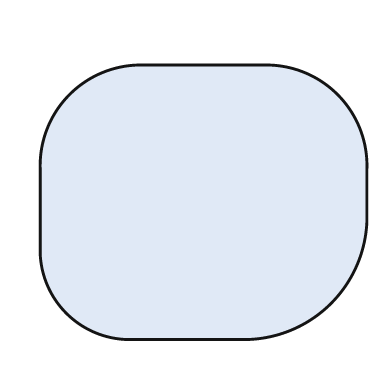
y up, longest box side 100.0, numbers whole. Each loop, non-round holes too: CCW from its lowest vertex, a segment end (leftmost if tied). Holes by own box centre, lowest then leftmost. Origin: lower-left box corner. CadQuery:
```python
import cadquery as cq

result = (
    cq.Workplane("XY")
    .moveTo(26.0, 0.0)
    .lineTo(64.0, 0.0)
    .threePointArc((89.0, 11.0), (100.0, 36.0))
    .lineTo(100.0, 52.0)
    .threePointArc((91.0, 75.0), (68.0, 84.0))
    .lineTo(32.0, 84.0)
    .threePointArc((9.0, 75.0), (0.0, 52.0))
    .lineTo(0.0, 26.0)
    .threePointArc((8.0, 8.0), (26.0, 0.0))
    .close()
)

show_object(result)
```